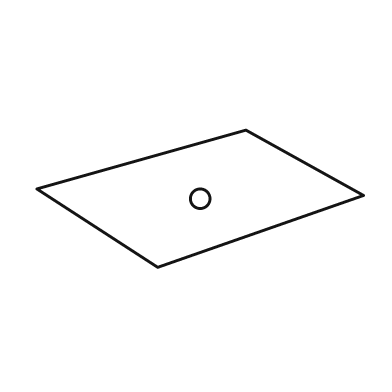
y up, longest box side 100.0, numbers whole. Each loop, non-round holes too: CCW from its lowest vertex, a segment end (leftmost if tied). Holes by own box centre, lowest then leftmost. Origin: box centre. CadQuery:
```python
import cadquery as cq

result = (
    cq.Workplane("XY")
    .moveTo(-13.0, -21.0)
    .lineTo(50.0, 1.0)
    .lineTo(14.0, 21.0)
    .lineTo(-50.0, 3.0)
    .close()
    .moveTo(0.0, 0.0)
    .circle(3.0)
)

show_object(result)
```